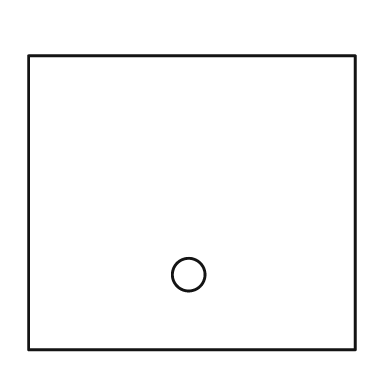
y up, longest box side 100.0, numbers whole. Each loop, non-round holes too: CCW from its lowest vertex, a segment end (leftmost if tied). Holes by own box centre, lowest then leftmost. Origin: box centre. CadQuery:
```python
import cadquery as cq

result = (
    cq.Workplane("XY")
    .moveTo(-50.0, -45.0)
    .lineTo(50.0, -45.0)
    .lineTo(50.0, 45.0)
    .lineTo(-50.0, 45.0)
    .close()
    .moveTo(-1.0, -22.0)
    .circle(5.0)
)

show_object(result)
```